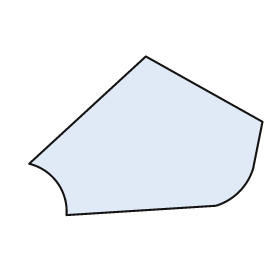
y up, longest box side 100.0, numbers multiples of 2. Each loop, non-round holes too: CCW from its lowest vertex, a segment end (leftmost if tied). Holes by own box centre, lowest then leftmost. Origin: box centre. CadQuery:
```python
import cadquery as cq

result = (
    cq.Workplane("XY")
    .moveTo(-34.0, -34.0)
    .lineTo(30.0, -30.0)
    .threePointArc((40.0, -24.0), (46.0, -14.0))
    .lineTo(50.0, 6.0)
    .lineTo(0.0, 34.0)
    .lineTo(-50.0, -12.0)
    .threePointArc((-38.0, -20.0), (-34.0, -34.0))
    .close()
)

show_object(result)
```